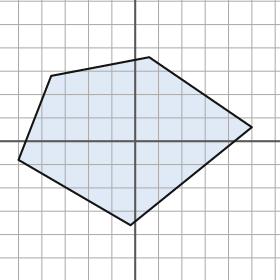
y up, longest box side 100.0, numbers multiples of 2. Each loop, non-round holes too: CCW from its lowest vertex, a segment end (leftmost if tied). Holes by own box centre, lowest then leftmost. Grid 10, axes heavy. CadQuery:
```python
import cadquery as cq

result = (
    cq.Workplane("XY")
    .moveTo(-2.0, -36.0)
    .lineTo(50.0, 6.0)
    .lineTo(6.0, 36.0)
    .lineTo(-36.0, 28.0)
    .lineTo(-50.0, -8.0)
    .close()
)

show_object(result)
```